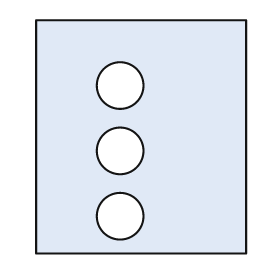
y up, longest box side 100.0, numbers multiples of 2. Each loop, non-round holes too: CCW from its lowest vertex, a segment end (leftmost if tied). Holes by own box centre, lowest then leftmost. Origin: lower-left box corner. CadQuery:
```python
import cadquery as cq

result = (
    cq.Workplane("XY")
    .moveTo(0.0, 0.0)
    .lineTo(90.0, 0.0)
    .lineTo(90.0, 100.0)
    .lineTo(0.0, 100.0)
    .close()
    .moveTo(36.0, 16.0)
    .circle(10.0)
    .moveTo(36.0, 44.0)
    .circle(10.0)
    .moveTo(36.0, 72.0)
    .circle(10.0)
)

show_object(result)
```